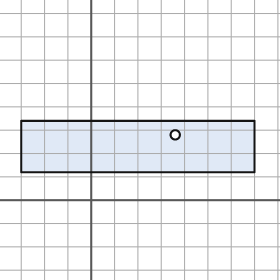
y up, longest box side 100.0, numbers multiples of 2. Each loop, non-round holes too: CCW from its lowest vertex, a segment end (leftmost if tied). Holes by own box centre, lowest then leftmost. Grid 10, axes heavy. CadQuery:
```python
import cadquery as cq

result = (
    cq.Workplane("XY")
    .moveTo(-30.0, 12.0)
    .lineTo(70.0, 12.0)
    .lineTo(70.0, 34.0)
    .lineTo(-30.0, 34.0)
    .close()
    .moveTo(36.0, 28.0)
    .circle(2.0)
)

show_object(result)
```